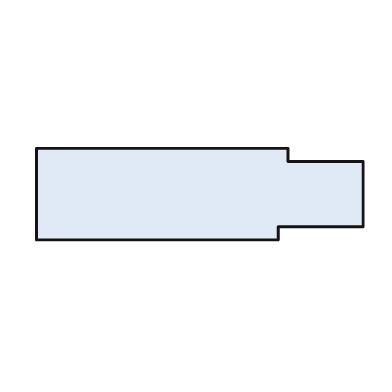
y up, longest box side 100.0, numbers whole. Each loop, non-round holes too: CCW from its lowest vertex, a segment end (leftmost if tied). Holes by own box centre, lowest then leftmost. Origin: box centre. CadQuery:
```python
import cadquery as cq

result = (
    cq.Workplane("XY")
    .moveTo(-50.0, -14.0)
    .lineTo(24.0, -14.0)
    .lineTo(24.0, -10.0)
    .lineTo(50.0, -10.0)
    .lineTo(50.0, 10.0)
    .lineTo(27.0, 10.0)
    .lineTo(27.0, 14.0)
    .lineTo(-50.0, 14.0)
    .close()
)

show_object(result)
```